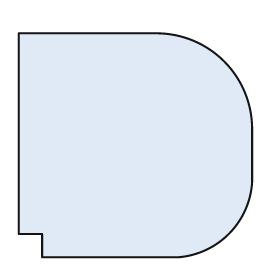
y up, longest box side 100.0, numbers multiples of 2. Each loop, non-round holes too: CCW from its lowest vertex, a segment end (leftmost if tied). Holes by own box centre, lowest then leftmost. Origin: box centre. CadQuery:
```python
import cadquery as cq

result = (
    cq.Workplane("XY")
    .moveTo(-40.0, -48.0)
    .lineTo(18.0, -48.0)
    .threePointArc((40.0, -38.0), (50.0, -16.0))
    .lineTo(50.0, 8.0)
    .threePointArc((38.0, 36.0), (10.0, 48.0))
    .lineTo(-50.0, 48.0)
    .lineTo(-50.0, -38.0)
    .lineTo(-40.0, -38.0)
    .close()
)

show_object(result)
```